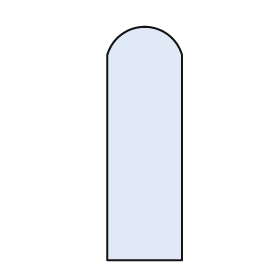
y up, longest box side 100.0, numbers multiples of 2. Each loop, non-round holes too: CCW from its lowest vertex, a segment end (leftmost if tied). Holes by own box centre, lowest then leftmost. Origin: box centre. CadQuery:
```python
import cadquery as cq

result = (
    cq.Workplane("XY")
    .moveTo(-16.0, -50.0)
    .lineTo(16.0, -50.0)
    .lineTo(16.0, 38.0)
    .threePointArc((0.0, 50.0), (-16.0, 38.0))
    .close()
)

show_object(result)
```